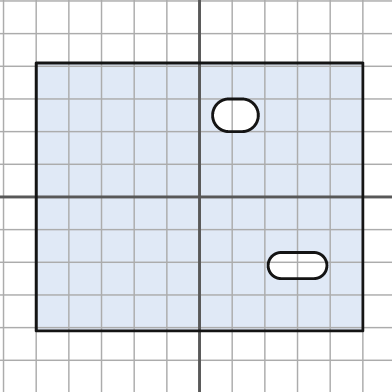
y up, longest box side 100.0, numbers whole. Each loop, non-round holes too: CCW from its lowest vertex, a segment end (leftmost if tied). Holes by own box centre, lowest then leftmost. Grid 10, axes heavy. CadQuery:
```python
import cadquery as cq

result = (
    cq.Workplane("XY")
    .moveTo(-50.0, -41.0)
    .lineTo(50.0, -41.0)
    .lineTo(50.0, 41.0)
    .lineTo(-50.0, 41.0)
    .close()
    .moveTo(25.0, -25.0)
    .lineTo(35.0, -25.0)
    .threePointArc((39.0, -21.0), (35.0, -17.0))
    .lineTo(25.0, -17.0)
    .threePointArc((21.0, -21.0), (25.0, -25.0))
    .close()
    .moveTo(9.0, 20.0)
    .lineTo(13.0, 20.0)
    .threePointArc((18.0, 25.0), (13.0, 30.0))
    .lineTo(9.0, 30.0)
    .threePointArc((4.0, 25.0), (9.0, 20.0))
    .close()
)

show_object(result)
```